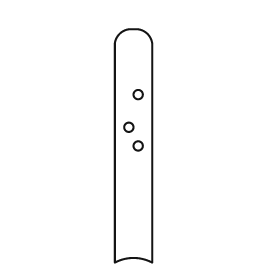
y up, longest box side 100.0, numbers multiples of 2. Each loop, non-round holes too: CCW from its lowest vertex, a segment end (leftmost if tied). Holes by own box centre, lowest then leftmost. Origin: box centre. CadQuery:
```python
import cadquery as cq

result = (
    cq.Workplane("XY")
    .moveTo(-8.0, -50.0)
    .threePointArc((0.0, -48.0), (8.0, -50.0))
    .lineTo(8.0, 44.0)
    .threePointArc((6.0, 48.0), (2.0, 50.0))
    .lineTo(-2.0, 50.0)
    .threePointArc((-6.0, 48.0), (-8.0, 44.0))
    .close()
    .moveTo(2.0, 0.0)
    .circle(2.0)
    .moveTo(-2.0, 8.0)
    .circle(2.0)
    .moveTo(2.0, 22.0)
    .circle(2.0)
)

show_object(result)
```